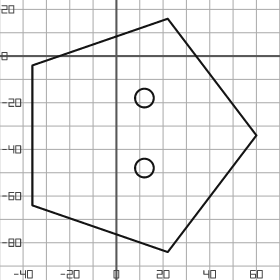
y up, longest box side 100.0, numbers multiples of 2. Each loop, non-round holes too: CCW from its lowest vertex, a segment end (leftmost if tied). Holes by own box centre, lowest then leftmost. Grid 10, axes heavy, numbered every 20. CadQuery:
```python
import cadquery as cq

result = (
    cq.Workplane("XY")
    .moveTo(22.0, -84.0)
    .lineTo(60.0, -34.0)
    .lineTo(22.0, 16.0)
    .lineTo(-36.0, -4.0)
    .lineTo(-36.0, -64.0)
    .close()
    .moveTo(12.0, -48.0)
    .circle(4.0)
    .moveTo(12.0, -18.0)
    .circle(4.0)
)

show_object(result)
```